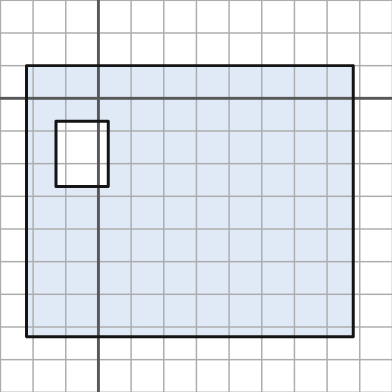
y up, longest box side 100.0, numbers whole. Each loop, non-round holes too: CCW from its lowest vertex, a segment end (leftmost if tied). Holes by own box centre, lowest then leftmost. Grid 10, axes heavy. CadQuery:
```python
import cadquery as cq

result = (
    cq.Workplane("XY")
    .moveTo(-22.0, -73.0)
    .lineTo(78.0, -73.0)
    .lineTo(78.0, 10.0)
    .lineTo(-22.0, 10.0)
    .close()
    .moveTo(-13.0, -27.0)
    .lineTo(3.0, -27.0)
    .lineTo(3.0, -7.0)
    .lineTo(-13.0, -7.0)
    .close()
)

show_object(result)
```